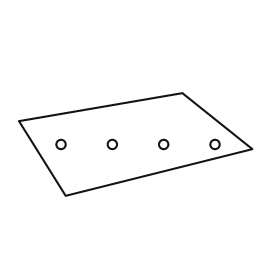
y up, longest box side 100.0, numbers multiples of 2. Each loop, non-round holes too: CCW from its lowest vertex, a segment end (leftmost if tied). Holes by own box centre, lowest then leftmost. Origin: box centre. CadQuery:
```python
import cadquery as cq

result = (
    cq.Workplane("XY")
    .moveTo(-30.0, -22.0)
    .lineTo(50.0, -2.0)
    .lineTo(20.0, 22.0)
    .lineTo(-50.0, 10.0)
    .close()
    .moveTo(-32.0, 0.0)
    .circle(2.0)
    .moveTo(-10.0, 0.0)
    .circle(2.0)
    .moveTo(12.0, 0.0)
    .circle(2.0)
    .moveTo(34.0, 0.0)
    .circle(2.0)
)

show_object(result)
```